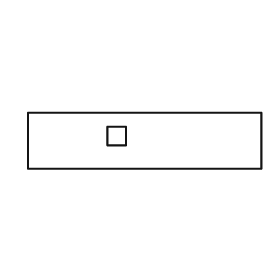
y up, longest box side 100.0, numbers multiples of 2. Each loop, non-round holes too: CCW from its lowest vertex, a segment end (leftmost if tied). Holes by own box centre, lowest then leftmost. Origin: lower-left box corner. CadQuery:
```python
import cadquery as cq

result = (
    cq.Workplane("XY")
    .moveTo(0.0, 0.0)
    .lineTo(100.0, 0.0)
    .lineTo(100.0, 24.0)
    .lineTo(0.0, 24.0)
    .close()
    .moveTo(34.0, 10.0)
    .lineTo(42.0, 10.0)
    .lineTo(42.0, 18.0)
    .lineTo(34.0, 18.0)
    .close()
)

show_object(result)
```